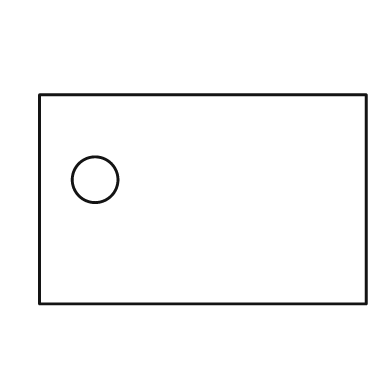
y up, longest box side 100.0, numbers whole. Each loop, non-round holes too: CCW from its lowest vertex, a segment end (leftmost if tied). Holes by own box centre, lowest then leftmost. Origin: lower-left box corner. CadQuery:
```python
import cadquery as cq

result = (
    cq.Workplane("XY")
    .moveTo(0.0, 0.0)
    .lineTo(100.0, 0.0)
    .lineTo(100.0, 64.0)
    .lineTo(0.0, 64.0)
    .close()
    .moveTo(17.0, 38.0)
    .circle(7.0)
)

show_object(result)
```